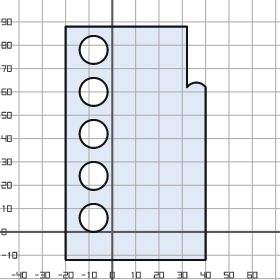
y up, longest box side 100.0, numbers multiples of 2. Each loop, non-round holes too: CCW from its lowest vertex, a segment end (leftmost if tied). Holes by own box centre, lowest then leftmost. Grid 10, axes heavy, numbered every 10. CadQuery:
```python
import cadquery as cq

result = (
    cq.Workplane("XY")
    .moveTo(-20.0, -12.0)
    .lineTo(40.0, -12.0)
    .lineTo(40.0, 62.0)
    .threePointArc((36.0, 64.0), (32.0, 62.0))
    .lineTo(32.0, 88.0)
    .lineTo(-20.0, 88.0)
    .close()
    .moveTo(-8.0, 6.0)
    .circle(6.0)
    .moveTo(-8.0, 24.0)
    .circle(6.0)
    .moveTo(-8.0, 42.0)
    .circle(6.0)
    .moveTo(-8.0, 60.0)
    .circle(6.0)
    .moveTo(-8.0, 78.0)
    .circle(6.0)
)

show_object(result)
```